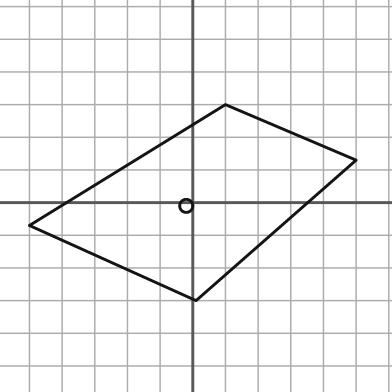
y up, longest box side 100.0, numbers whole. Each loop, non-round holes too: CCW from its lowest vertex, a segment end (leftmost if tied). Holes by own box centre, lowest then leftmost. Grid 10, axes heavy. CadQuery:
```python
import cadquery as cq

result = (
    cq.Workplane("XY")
    .moveTo(1.0, -30.0)
    .lineTo(50.0, 13.0)
    .lineTo(10.0, 30.0)
    .lineTo(-50.0, -7.0)
    .close()
    .moveTo(-2.0, -1.0)
    .circle(2.0)
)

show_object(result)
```